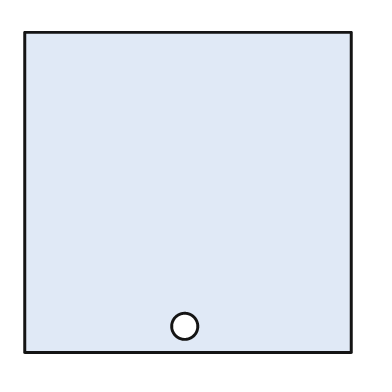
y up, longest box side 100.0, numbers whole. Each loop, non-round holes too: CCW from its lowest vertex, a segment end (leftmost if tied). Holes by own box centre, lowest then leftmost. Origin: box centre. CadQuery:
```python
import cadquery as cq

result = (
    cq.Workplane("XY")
    .moveTo(-50.0, -49.0)
    .lineTo(50.0, -49.0)
    .lineTo(50.0, 49.0)
    .lineTo(-50.0, 49.0)
    .close()
    .moveTo(-1.0, -41.0)
    .circle(4.0)
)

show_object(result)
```